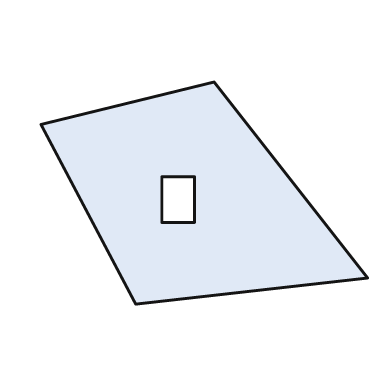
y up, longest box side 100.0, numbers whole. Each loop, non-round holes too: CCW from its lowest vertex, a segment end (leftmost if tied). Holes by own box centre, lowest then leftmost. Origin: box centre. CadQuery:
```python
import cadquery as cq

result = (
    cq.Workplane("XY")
    .moveTo(-21.0, -34.0)
    .lineTo(50.0, -26.0)
    .lineTo(3.0, 34.0)
    .lineTo(-50.0, 21.0)
    .close()
    .moveTo(-13.0, -9.0)
    .lineTo(-3.0, -9.0)
    .lineTo(-3.0, 5.0)
    .lineTo(-13.0, 5.0)
    .close()
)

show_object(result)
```